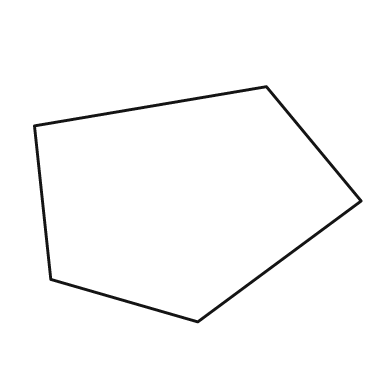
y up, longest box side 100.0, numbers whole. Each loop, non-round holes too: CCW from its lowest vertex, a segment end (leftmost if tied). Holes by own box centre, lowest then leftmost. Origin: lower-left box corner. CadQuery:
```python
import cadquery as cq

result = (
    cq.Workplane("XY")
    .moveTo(50.0, 0.0)
    .lineTo(100.0, 37.0)
    .lineTo(71.0, 72.0)
    .lineTo(0.0, 60.0)
    .lineTo(5.0, 13.0)
    .close()
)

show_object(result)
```